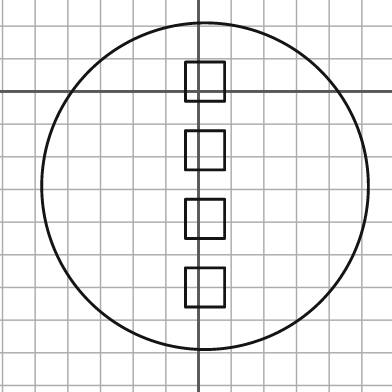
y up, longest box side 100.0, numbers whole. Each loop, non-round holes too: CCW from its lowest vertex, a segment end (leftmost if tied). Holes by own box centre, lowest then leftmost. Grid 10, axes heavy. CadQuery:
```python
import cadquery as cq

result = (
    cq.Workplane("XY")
    .moveTo(2.0, -29.0)
    .circle(50.0)
    .moveTo(-4.0, -66.0)
    .lineTo(8.0, -66.0)
    .lineTo(8.0, -54.0)
    .lineTo(-4.0, -54.0)
    .close()
    .moveTo(-4.0, -45.0)
    .lineTo(8.0, -45.0)
    .lineTo(8.0, -33.0)
    .lineTo(-4.0, -33.0)
    .close()
    .moveTo(-4.0, -24.0)
    .lineTo(8.0, -24.0)
    .lineTo(8.0, -12.0)
    .lineTo(-4.0, -12.0)
    .close()
    .moveTo(-4.0, -3.0)
    .lineTo(8.0, -3.0)
    .lineTo(8.0, 9.0)
    .lineTo(-4.0, 9.0)
    .close()
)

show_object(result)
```